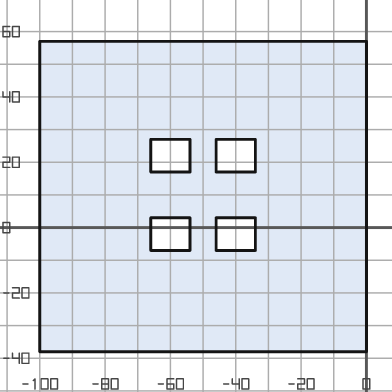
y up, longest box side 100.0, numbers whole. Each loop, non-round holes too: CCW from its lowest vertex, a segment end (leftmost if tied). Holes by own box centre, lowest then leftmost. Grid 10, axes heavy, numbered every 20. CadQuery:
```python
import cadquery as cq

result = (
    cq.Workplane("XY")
    .moveTo(-100.0, -38.0)
    .lineTo(0.0, -38.0)
    .lineTo(0.0, 57.0)
    .lineTo(-100.0, 57.0)
    .close()
    .moveTo(-66.0, -7.0)
    .lineTo(-54.0, -7.0)
    .lineTo(-54.0, 3.0)
    .lineTo(-66.0, 3.0)
    .close()
    .moveTo(-46.0, -7.0)
    .lineTo(-34.0, -7.0)
    .lineTo(-34.0, 3.0)
    .lineTo(-46.0, 3.0)
    .close()
    .moveTo(-66.0, 17.0)
    .lineTo(-54.0, 17.0)
    .lineTo(-54.0, 27.0)
    .lineTo(-66.0, 27.0)
    .close()
    .moveTo(-46.0, 17.0)
    .lineTo(-34.0, 17.0)
    .lineTo(-34.0, 27.0)
    .lineTo(-46.0, 27.0)
    .close()
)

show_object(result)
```